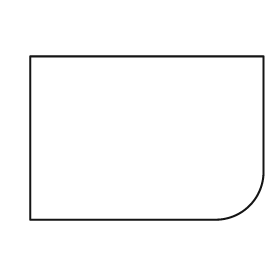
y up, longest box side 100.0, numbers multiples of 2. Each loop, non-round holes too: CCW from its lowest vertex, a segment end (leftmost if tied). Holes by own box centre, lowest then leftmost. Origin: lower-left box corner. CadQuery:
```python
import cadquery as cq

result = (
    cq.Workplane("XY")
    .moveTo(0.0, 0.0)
    .lineTo(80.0, 0.0)
    .threePointArc((94.0, 6.0), (100.0, 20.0))
    .lineTo(100.0, 70.0)
    .lineTo(0.0, 70.0)
    .close()
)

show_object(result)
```